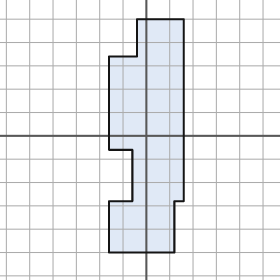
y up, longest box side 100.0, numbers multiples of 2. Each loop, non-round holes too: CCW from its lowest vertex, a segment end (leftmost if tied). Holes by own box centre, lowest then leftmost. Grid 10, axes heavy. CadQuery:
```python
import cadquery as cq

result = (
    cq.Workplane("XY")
    .moveTo(-16.0, -50.0)
    .lineTo(12.0, -50.0)
    .lineTo(12.0, -28.0)
    .lineTo(16.0, -28.0)
    .lineTo(16.0, 50.0)
    .lineTo(-4.0, 50.0)
    .lineTo(-4.0, 34.0)
    .lineTo(-16.0, 34.0)
    .lineTo(-16.0, -6.0)
    .lineTo(-6.0, -6.0)
    .lineTo(-6.0, -28.0)
    .lineTo(-16.0, -28.0)
    .close()
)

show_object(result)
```